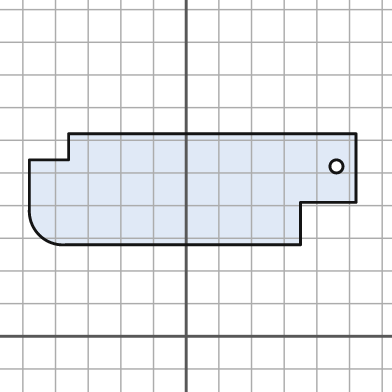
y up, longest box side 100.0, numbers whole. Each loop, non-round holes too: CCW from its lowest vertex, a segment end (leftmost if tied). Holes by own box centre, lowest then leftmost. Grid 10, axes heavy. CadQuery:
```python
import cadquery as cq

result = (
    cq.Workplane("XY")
    .moveTo(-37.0, 28.0)
    .lineTo(35.0, 28.0)
    .lineTo(35.0, 41.0)
    .lineTo(52.0, 41.0)
    .lineTo(52.0, 62.0)
    .lineTo(-36.0, 62.0)
    .lineTo(-36.0, 54.0)
    .lineTo(-48.0, 54.0)
    .lineTo(-48.0, 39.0)
    .threePointArc((-45.0, 31.0), (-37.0, 28.0))
    .close()
    .moveTo(46.0, 52.0)
    .circle(2.0)
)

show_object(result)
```